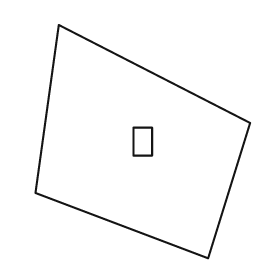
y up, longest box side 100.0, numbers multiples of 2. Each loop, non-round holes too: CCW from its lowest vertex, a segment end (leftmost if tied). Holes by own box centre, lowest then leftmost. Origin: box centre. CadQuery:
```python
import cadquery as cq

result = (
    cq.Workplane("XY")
    .moveTo(28.0, -50.0)
    .lineTo(46.0, 8.0)
    .lineTo(-36.0, 50.0)
    .lineTo(-46.0, -22.0)
    .close()
    .moveTo(-4.0, -6.0)
    .lineTo(4.0, -6.0)
    .lineTo(4.0, 6.0)
    .lineTo(-4.0, 6.0)
    .close()
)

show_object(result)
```